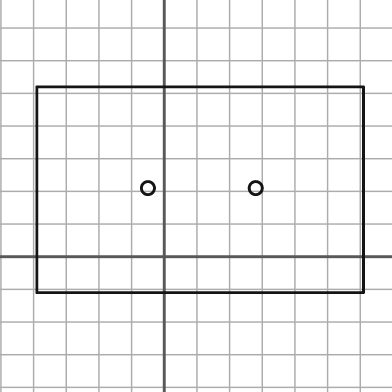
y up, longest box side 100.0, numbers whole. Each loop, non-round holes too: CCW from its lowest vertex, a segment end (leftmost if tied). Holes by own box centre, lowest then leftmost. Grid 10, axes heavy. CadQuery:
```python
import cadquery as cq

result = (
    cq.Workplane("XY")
    .moveTo(-39.0, -11.0)
    .lineTo(61.0, -11.0)
    .lineTo(61.0, 52.0)
    .lineTo(-39.0, 52.0)
    .close()
    .moveTo(-5.0, 21.0)
    .circle(2.0)
    .moveTo(28.0, 21.0)
    .circle(2.0)
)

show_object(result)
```